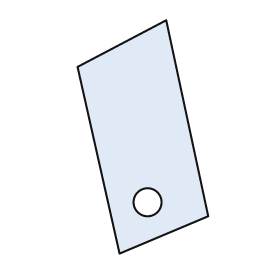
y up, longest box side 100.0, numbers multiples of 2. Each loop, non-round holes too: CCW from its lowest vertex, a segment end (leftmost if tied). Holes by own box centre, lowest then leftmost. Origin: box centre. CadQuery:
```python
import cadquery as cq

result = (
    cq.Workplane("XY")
    .moveTo(-10.0, -50.0)
    .lineTo(28.0, -34.0)
    .lineTo(10.0, 50.0)
    .lineTo(-28.0, 30.0)
    .close()
    .moveTo(2.0, -28.0)
    .circle(6.0)
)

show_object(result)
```